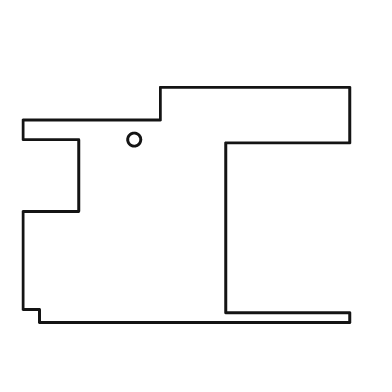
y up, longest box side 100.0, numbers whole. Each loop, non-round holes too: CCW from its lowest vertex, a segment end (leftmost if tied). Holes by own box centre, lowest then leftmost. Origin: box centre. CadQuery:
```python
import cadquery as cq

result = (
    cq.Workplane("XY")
    .moveTo(-45.0, -36.0)
    .lineTo(50.0, -36.0)
    .lineTo(50.0, -33.0)
    .lineTo(12.0, -33.0)
    .lineTo(12.0, 19.0)
    .lineTo(50.0, 19.0)
    .lineTo(50.0, 36.0)
    .lineTo(-8.0, 36.0)
    .lineTo(-8.0, 26.0)
    .lineTo(-50.0, 26.0)
    .lineTo(-50.0, 20.0)
    .lineTo(-33.0, 20.0)
    .lineTo(-33.0, -2.0)
    .lineTo(-50.0, -2.0)
    .lineTo(-50.0, -32.0)
    .lineTo(-45.0, -32.0)
    .close()
    .moveTo(-16.0, 20.0)
    .circle(2.0)
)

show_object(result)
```